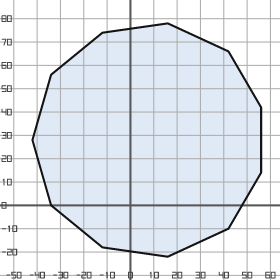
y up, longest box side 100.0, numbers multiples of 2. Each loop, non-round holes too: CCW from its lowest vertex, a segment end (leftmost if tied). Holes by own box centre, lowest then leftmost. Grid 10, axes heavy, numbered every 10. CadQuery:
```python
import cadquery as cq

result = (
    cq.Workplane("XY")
    .moveTo(16.0, -22.0)
    .lineTo(42.0, -10.0)
    .lineTo(56.0, 14.0)
    .lineTo(56.0, 42.0)
    .lineTo(42.0, 66.0)
    .lineTo(16.0, 78.0)
    .lineTo(-12.0, 74.0)
    .lineTo(-34.0, 56.0)
    .lineTo(-42.0, 28.0)
    .lineTo(-34.0, 0.0)
    .lineTo(-12.0, -18.0)
    .close()
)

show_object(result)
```